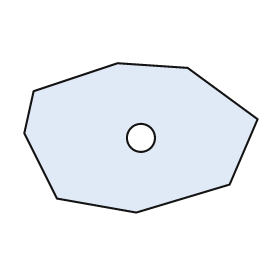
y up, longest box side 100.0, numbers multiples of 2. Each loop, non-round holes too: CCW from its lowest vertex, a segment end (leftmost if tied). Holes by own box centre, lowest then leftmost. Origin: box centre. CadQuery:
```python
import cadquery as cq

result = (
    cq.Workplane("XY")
    .moveTo(-2.0, -32.0)
    .lineTo(38.0, -20.0)
    .lineTo(50.0, 8.0)
    .lineTo(20.0, 30.0)
    .lineTo(-10.0, 32.0)
    .lineTo(-46.0, 20.0)
    .lineTo(-50.0, 2.0)
    .lineTo(-36.0, -26.0)
    .close()
    .moveTo(0.0, 0.0)
    .circle(6.0)
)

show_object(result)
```